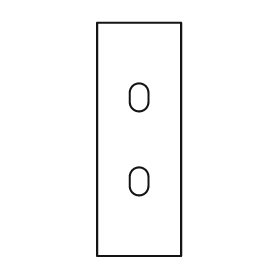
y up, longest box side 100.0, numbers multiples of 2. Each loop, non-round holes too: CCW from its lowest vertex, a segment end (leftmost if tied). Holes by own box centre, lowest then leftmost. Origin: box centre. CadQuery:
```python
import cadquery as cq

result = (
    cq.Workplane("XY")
    .moveTo(-18.0, -50.0)
    .lineTo(18.0, -50.0)
    .lineTo(18.0, 50.0)
    .lineTo(-18.0, 50.0)
    .close()
    .moveTo(-4.0, -20.0)
    .threePointArc((0.0, -24.0), (4.0, -20.0))
    .lineTo(4.0, -16.0)
    .threePointArc((0.0, -12.0), (-4.0, -16.0))
    .close()
    .moveTo(-4.0, 16.0)
    .threePointArc((0.0, 12.0), (4.0, 16.0))
    .lineTo(4.0, 20.0)
    .threePointArc((0.0, 24.0), (-4.0, 20.0))
    .close()
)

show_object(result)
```